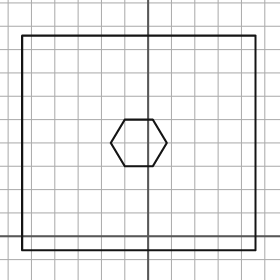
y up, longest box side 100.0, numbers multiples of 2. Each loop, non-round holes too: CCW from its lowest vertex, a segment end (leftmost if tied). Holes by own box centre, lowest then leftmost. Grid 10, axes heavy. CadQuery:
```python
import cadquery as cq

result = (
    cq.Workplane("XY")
    .moveTo(-54.0, -6.0)
    .lineTo(46.0, -6.0)
    .lineTo(46.0, 86.0)
    .lineTo(-54.0, 86.0)
    .close()
    .moveTo(-10.0, 30.0)
    .lineTo(2.0, 30.0)
    .lineTo(8.0, 40.0)
    .lineTo(2.0, 50.0)
    .lineTo(-10.0, 50.0)
    .lineTo(-16.0, 40.0)
    .close()
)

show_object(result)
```